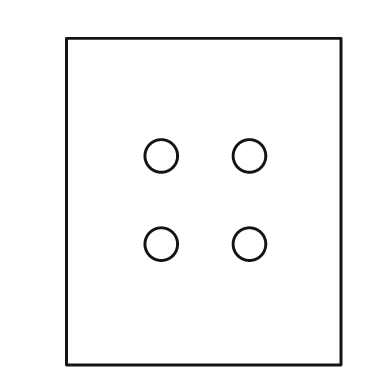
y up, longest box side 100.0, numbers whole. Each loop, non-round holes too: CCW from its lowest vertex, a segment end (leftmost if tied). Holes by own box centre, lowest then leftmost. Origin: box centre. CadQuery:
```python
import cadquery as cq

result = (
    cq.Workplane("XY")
    .moveTo(-42.0, -50.0)
    .lineTo(42.0, -50.0)
    .lineTo(42.0, 50.0)
    .lineTo(-42.0, 50.0)
    .close()
    .moveTo(-13.0, -13.0)
    .circle(5.0)
    .moveTo(14.0, -13.0)
    .circle(5.0)
    .moveTo(-13.0, 14.0)
    .circle(5.0)
    .moveTo(14.0, 14.0)
    .circle(5.0)
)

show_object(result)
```